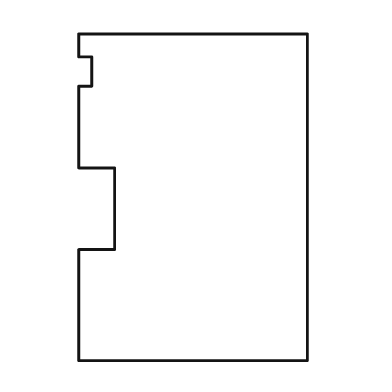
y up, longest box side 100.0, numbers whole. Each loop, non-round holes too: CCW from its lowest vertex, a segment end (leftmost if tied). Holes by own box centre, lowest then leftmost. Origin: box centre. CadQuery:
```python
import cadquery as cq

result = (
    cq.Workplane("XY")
    .moveTo(-35.0, -50.0)
    .lineTo(35.0, -50.0)
    .lineTo(35.0, 50.0)
    .lineTo(-35.0, 50.0)
    .lineTo(-35.0, 43.0)
    .lineTo(-31.0, 43.0)
    .lineTo(-31.0, 34.0)
    .lineTo(-35.0, 34.0)
    .lineTo(-35.0, 9.0)
    .lineTo(-24.0, 9.0)
    .lineTo(-24.0, -16.0)
    .lineTo(-35.0, -16.0)
    .close()
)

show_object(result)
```